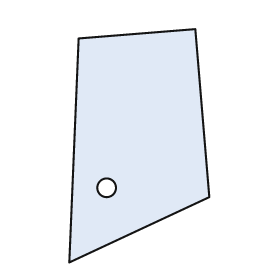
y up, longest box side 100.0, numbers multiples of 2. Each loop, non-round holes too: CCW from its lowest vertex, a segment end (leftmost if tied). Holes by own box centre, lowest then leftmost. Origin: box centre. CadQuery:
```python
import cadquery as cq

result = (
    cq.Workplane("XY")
    .moveTo(-30.0, -50.0)
    .lineTo(30.0, -22.0)
    .lineTo(24.0, 50.0)
    .lineTo(-26.0, 46.0)
    .close()
    .moveTo(-14.0, -18.0)
    .circle(4.0)
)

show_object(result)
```